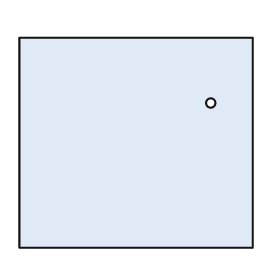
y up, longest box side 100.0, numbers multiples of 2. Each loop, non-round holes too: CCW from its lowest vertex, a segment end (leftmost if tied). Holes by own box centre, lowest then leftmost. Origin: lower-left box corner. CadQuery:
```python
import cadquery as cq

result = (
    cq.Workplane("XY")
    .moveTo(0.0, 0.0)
    .lineTo(100.0, 0.0)
    .lineTo(100.0, 90.0)
    .lineTo(0.0, 90.0)
    .close()
    .moveTo(82.0, 62.0)
    .circle(2.0)
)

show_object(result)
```